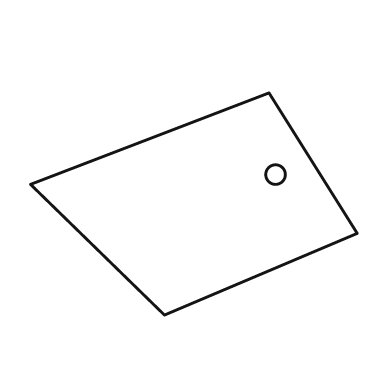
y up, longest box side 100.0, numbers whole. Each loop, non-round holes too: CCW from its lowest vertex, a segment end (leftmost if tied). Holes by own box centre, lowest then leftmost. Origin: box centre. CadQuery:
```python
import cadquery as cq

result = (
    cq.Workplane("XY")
    .moveTo(-9.0, -34.0)
    .lineTo(50.0, -9.0)
    .lineTo(23.0, 34.0)
    .lineTo(-50.0, 6.0)
    .close()
    .moveTo(25.0, 9.0)
    .circle(3.0)
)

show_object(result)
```